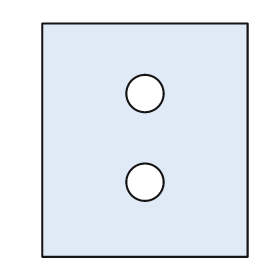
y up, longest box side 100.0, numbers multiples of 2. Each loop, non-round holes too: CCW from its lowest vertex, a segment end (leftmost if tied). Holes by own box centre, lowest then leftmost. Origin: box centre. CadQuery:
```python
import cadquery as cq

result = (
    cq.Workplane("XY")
    .moveTo(-44.0, -50.0)
    .lineTo(44.0, -50.0)
    .lineTo(44.0, 50.0)
    .lineTo(-44.0, 50.0)
    .close()
    .moveTo(0.0, -18.0)
    .circle(8.0)
    .moveTo(0.0, 20.0)
    .circle(8.0)
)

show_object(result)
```